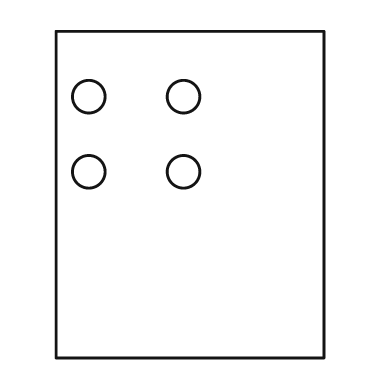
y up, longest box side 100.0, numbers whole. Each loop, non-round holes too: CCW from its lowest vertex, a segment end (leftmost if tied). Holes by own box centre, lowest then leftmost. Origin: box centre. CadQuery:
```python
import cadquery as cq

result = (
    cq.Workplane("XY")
    .moveTo(-41.0, -50.0)
    .lineTo(41.0, -50.0)
    .lineTo(41.0, 50.0)
    .lineTo(-41.0, 50.0)
    .close()
    .moveTo(-31.0, 7.0)
    .circle(5.0)
    .moveTo(-2.0, 7.0)
    .circle(5.0)
    .moveTo(-31.0, 30.0)
    .circle(5.0)
    .moveTo(-2.0, 30.0)
    .circle(5.0)
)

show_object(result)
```